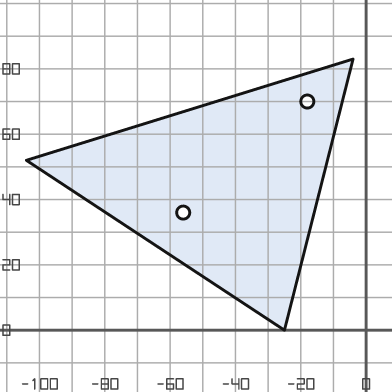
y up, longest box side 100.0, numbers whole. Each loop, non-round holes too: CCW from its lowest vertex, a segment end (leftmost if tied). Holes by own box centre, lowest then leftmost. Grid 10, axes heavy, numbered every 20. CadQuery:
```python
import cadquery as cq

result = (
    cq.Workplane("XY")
    .moveTo(-25.0, 0.0)
    .lineTo(-4.0, 83.0)
    .lineTo(-104.0, 52.0)
    .close()
    .moveTo(-56.0, 36.0)
    .circle(2.0)
    .moveTo(-18.0, 70.0)
    .circle(2.0)
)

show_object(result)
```